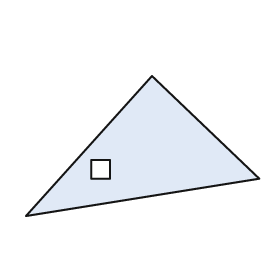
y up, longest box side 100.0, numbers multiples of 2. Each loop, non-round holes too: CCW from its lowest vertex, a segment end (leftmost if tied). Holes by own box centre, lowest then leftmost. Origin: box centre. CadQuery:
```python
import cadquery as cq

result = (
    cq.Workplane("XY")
    .moveTo(-50.0, -30.0)
    .lineTo(50.0, -14.0)
    .lineTo(4.0, 30.0)
    .close()
    .moveTo(-22.0, -14.0)
    .lineTo(-14.0, -14.0)
    .lineTo(-14.0, -6.0)
    .lineTo(-22.0, -6.0)
    .close()
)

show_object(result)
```